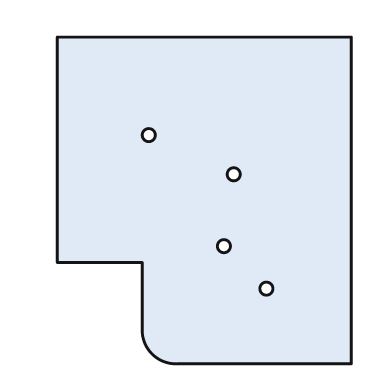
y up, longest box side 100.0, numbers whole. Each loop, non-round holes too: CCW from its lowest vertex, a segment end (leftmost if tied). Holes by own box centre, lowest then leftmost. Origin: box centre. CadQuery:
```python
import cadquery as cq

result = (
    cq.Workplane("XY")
    .moveTo(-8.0, -50.0)
    .lineTo(45.0, -50.0)
    .lineTo(45.0, 50.0)
    .lineTo(-45.0, 50.0)
    .lineTo(-45.0, -19.0)
    .lineTo(-19.0, -19.0)
    .lineTo(-19.0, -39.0)
    .threePointArc((-16.0, -47.0), (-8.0, -50.0))
    .close()
    .moveTo(19.0, -27.0)
    .circle(2.0)
    .moveTo(6.0, -14.0)
    .circle(2.0)
    .moveTo(9.0, 8.0)
    .circle(2.0)
    .moveTo(-17.0, 20.0)
    .circle(2.0)
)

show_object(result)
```